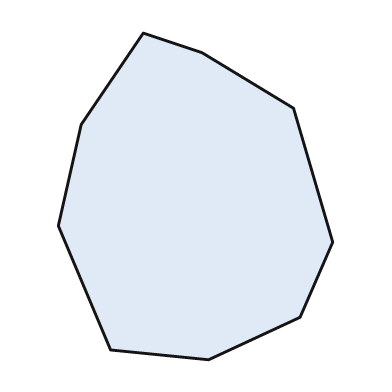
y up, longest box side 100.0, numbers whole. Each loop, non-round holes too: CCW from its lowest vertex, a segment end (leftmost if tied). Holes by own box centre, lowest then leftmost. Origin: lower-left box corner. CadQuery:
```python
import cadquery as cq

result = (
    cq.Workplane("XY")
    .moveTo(46.0, 0.0)
    .lineTo(74.0, 13.0)
    .lineTo(84.0, 36.0)
    .lineTo(72.0, 77.0)
    .lineTo(44.0, 94.0)
    .lineTo(26.0, 100.0)
    .lineTo(7.0, 72.0)
    .lineTo(0.0, 41.0)
    .lineTo(16.0, 3.0)
    .close()
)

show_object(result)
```